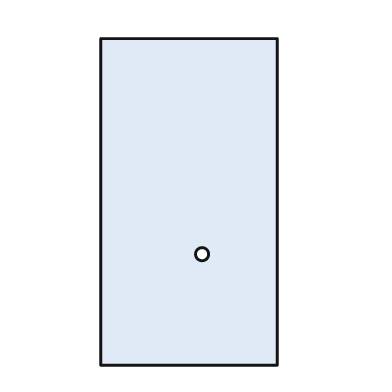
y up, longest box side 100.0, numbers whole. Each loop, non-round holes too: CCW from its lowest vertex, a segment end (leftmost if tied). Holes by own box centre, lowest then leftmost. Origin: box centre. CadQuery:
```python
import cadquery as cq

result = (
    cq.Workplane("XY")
    .moveTo(-27.0, -50.0)
    .lineTo(27.0, -50.0)
    .lineTo(27.0, 50.0)
    .lineTo(-27.0, 50.0)
    .close()
    .moveTo(4.0, -16.0)
    .circle(2.0)
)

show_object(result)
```